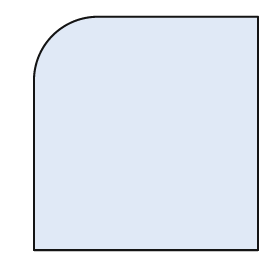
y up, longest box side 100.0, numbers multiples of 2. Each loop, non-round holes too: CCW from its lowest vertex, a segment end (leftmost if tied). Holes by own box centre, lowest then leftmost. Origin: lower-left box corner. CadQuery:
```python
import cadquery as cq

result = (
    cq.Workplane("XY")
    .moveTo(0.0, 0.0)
    .lineTo(96.0, 0.0)
    .lineTo(96.0, 100.0)
    .lineTo(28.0, 100.0)
    .threePointArc((8.0, 92.0), (0.0, 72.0))
    .close()
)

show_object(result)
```